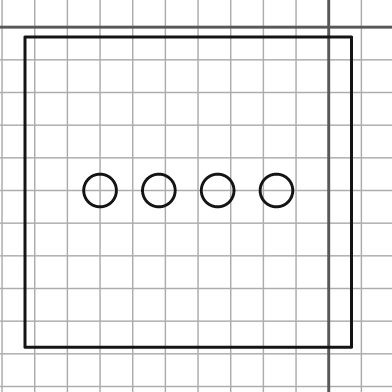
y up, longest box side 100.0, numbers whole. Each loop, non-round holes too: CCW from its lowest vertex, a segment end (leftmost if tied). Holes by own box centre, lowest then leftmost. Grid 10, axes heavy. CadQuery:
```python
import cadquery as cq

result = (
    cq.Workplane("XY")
    .moveTo(-93.0, -98.0)
    .lineTo(7.0, -98.0)
    .lineTo(7.0, -3.0)
    .lineTo(-93.0, -3.0)
    .close()
    .moveTo(-70.0, -50.0)
    .circle(5.0)
    .moveTo(-52.0, -50.0)
    .circle(5.0)
    .moveTo(-34.0, -50.0)
    .circle(5.0)
    .moveTo(-16.0, -50.0)
    .circle(5.0)
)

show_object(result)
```